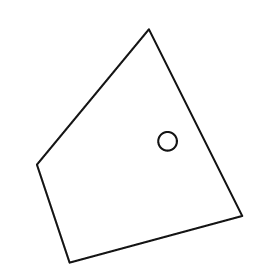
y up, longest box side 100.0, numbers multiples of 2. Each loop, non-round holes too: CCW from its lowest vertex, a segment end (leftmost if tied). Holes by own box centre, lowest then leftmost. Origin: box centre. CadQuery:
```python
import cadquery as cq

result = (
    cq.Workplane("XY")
    .moveTo(-30.0, -50.0)
    .lineTo(44.0, -30.0)
    .lineTo(4.0, 50.0)
    .lineTo(-44.0, -8.0)
    .close()
    .moveTo(12.0, 2.0)
    .circle(4.0)
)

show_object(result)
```